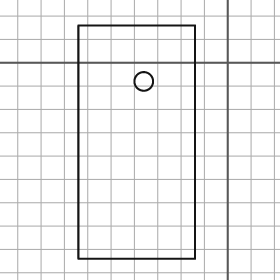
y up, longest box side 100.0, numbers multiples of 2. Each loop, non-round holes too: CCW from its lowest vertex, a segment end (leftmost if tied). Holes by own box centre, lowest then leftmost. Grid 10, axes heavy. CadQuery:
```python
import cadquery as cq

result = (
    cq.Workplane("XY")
    .moveTo(-64.0, -84.0)
    .lineTo(-14.0, -84.0)
    .lineTo(-14.0, 16.0)
    .lineTo(-64.0, 16.0)
    .close()
    .moveTo(-36.0, -8.0)
    .circle(4.0)
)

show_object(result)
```